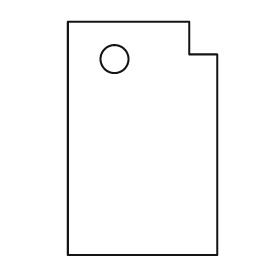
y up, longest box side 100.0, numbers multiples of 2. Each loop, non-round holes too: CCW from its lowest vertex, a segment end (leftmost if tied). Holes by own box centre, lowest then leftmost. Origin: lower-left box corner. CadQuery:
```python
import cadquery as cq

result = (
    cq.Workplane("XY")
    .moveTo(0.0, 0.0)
    .lineTo(64.0, 0.0)
    .lineTo(64.0, 86.0)
    .lineTo(52.0, 86.0)
    .lineTo(52.0, 100.0)
    .lineTo(0.0, 100.0)
    .close()
    .moveTo(20.0, 84.0)
    .circle(6.0)
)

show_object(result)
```